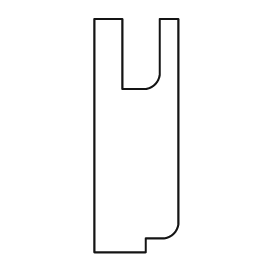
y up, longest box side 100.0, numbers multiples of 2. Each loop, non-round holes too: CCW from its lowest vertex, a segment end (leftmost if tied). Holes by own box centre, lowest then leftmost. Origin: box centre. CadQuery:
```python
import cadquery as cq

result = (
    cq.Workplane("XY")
    .moveTo(-18.0, -50.0)
    .lineTo(4.0, -50.0)
    .lineTo(4.0, -44.0)
    .lineTo(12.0, -44.0)
    .threePointArc((16.0, -42.0), (18.0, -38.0))
    .lineTo(18.0, 50.0)
    .lineTo(10.0, 50.0)
    .lineTo(10.0, 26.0)
    .threePointArc((8.0, 22.0), (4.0, 20.0))
    .lineTo(-6.0, 20.0)
    .lineTo(-6.0, 50.0)
    .lineTo(-18.0, 50.0)
    .close()
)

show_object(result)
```